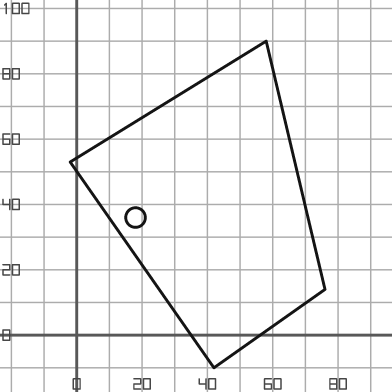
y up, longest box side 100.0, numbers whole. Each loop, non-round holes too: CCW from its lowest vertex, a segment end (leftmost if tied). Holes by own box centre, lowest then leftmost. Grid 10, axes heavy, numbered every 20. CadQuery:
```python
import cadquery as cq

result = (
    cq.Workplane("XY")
    .moveTo(42.0, -10.0)
    .lineTo(76.0, 14.0)
    .lineTo(58.0, 90.0)
    .lineTo(-2.0, 53.0)
    .close()
    .moveTo(18.0, 36.0)
    .circle(3.0)
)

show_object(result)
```